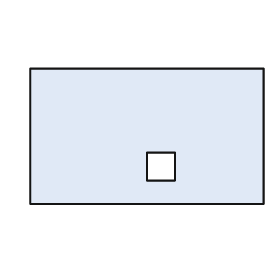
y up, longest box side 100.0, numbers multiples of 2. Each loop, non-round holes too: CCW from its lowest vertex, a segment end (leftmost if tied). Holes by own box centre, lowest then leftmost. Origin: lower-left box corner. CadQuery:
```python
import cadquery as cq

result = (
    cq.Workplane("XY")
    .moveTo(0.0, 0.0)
    .lineTo(100.0, 0.0)
    .lineTo(100.0, 58.0)
    .lineTo(0.0, 58.0)
    .close()
    .moveTo(50.0, 10.0)
    .lineTo(62.0, 10.0)
    .lineTo(62.0, 22.0)
    .lineTo(50.0, 22.0)
    .close()
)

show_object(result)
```